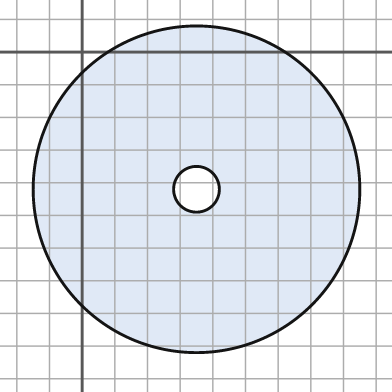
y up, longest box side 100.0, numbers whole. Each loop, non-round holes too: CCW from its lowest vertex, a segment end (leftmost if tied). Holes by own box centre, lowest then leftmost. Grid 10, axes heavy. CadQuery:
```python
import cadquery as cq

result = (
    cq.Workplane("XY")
    .moveTo(35.0, -42.0)
    .circle(50.0)
    .moveTo(35.0, -42.0)
    .circle(7.0)
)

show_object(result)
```